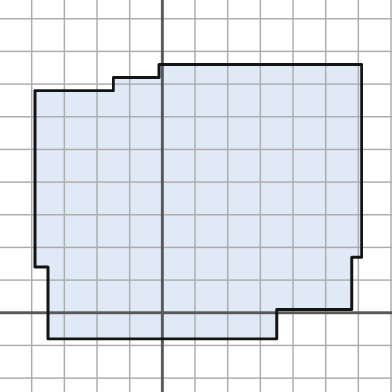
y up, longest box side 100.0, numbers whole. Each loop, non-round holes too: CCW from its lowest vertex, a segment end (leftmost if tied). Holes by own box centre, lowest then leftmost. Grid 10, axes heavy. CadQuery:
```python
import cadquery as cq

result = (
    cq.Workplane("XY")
    .moveTo(-35.0, -8.0)
    .lineTo(35.0, -8.0)
    .lineTo(35.0, 1.0)
    .lineTo(58.0, 1.0)
    .lineTo(58.0, 17.0)
    .lineTo(61.0, 17.0)
    .lineTo(61.0, 76.0)
    .lineTo(-1.0, 76.0)
    .lineTo(-1.0, 72.0)
    .lineTo(-15.0, 72.0)
    .lineTo(-15.0, 68.0)
    .lineTo(-39.0, 68.0)
    .lineTo(-39.0, 14.0)
    .lineTo(-35.0, 14.0)
    .close()
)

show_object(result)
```